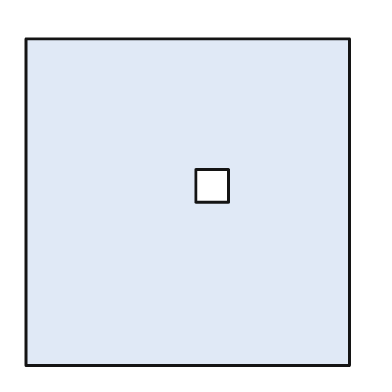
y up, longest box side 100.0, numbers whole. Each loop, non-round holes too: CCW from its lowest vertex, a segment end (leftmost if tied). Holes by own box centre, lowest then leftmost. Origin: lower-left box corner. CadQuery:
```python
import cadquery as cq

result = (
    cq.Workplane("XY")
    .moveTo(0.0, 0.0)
    .lineTo(99.0, 0.0)
    .lineTo(99.0, 100.0)
    .lineTo(0.0, 100.0)
    .close()
    .moveTo(52.0, 50.0)
    .lineTo(62.0, 50.0)
    .lineTo(62.0, 60.0)
    .lineTo(52.0, 60.0)
    .close()
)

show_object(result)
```